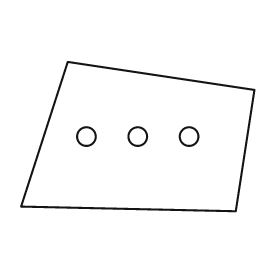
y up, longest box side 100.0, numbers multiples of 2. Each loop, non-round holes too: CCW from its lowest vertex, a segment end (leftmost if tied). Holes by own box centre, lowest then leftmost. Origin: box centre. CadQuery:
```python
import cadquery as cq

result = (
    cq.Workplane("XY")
    .moveTo(42.0, -32.0)
    .lineTo(50.0, 20.0)
    .lineTo(-30.0, 32.0)
    .lineTo(-50.0, -30.0)
    .close()
    .moveTo(-22.0, 0.0)
    .circle(4.0)
    .moveTo(0.0, 0.0)
    .circle(4.0)
    .moveTo(22.0, 0.0)
    .circle(4.0)
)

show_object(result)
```